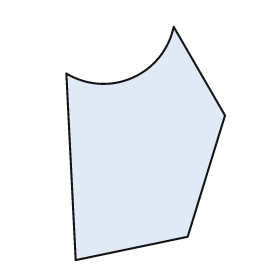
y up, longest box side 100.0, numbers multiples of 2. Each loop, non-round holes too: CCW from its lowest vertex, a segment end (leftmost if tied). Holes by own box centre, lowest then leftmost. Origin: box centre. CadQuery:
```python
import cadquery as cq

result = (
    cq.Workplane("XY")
    .moveTo(-30.0, -50.0)
    .lineTo(18.0, -40.0)
    .lineTo(34.0, 12.0)
    .lineTo(12.0, 50.0)
    .threePointArc((-6.0, 28.0), (-34.0, 30.0))
    .close()
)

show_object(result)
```